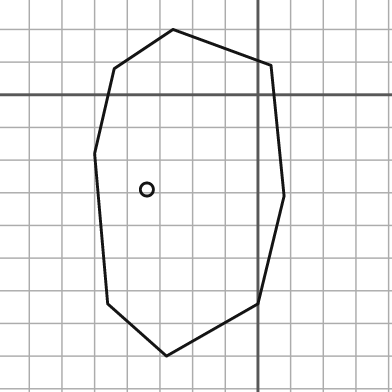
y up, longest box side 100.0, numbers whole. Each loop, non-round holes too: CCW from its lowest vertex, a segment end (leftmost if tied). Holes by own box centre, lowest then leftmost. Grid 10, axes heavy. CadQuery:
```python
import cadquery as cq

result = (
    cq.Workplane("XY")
    .moveTo(-28.0, -80.0)
    .lineTo(0.0, -64.0)
    .lineTo(8.0, -31.0)
    .lineTo(4.0, 9.0)
    .lineTo(-26.0, 20.0)
    .lineTo(-44.0, 8.0)
    .lineTo(-50.0, -18.0)
    .lineTo(-46.0, -64.0)
    .close()
    .moveTo(-34.0, -29.0)
    .circle(2.0)
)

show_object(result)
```